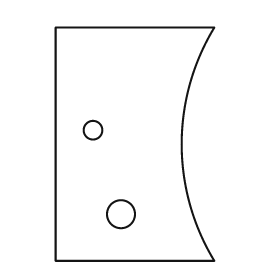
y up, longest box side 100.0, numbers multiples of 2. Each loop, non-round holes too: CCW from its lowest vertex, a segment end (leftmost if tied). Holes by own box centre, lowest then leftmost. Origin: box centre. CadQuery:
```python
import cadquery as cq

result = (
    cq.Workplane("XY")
    .moveTo(-34.0, -50.0)
    .lineTo(34.0, -50.0)
    .threePointArc((20.0, 0.0), (34.0, 50.0))
    .lineTo(-34.0, 50.0)
    .close()
    .moveTo(-6.0, -30.0)
    .circle(6.0)
    .moveTo(-18.0, 6.0)
    .circle(4.0)
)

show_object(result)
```